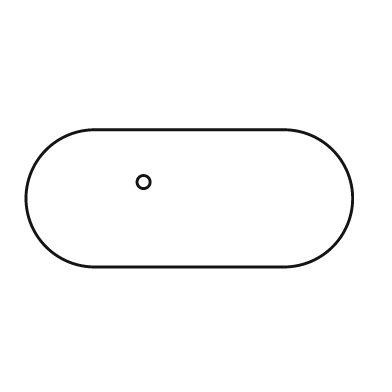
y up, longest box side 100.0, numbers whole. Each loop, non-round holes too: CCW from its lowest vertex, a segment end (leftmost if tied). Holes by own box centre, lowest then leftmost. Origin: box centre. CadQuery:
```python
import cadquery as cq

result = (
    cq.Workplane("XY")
    .moveTo(-29.0, -21.0)
    .lineTo(29.0, -21.0)
    .threePointArc((50.0, 0.0), (29.0, 21.0))
    .lineTo(-29.0, 21.0)
    .threePointArc((-50.0, 0.0), (-29.0, -21.0))
    .close()
    .moveTo(-14.0, 5.0)
    .circle(2.0)
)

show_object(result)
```